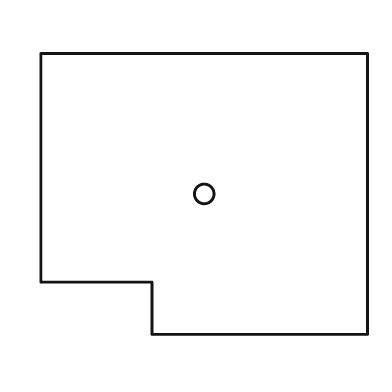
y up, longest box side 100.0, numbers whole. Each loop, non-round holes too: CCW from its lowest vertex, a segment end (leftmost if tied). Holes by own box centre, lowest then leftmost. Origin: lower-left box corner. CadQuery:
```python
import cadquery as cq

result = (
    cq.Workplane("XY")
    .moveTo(34.0, 0.0)
    .lineTo(100.0, 0.0)
    .lineTo(100.0, 86.0)
    .lineTo(0.0, 86.0)
    .lineTo(0.0, 16.0)
    .lineTo(34.0, 16.0)
    .close()
    .moveTo(50.0, 43.0)
    .circle(3.0)
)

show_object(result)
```